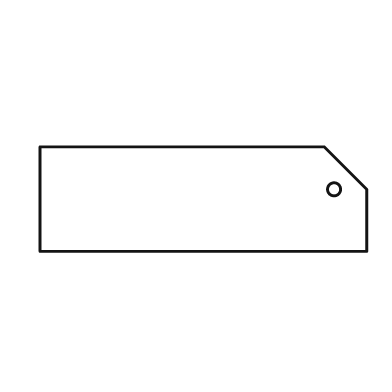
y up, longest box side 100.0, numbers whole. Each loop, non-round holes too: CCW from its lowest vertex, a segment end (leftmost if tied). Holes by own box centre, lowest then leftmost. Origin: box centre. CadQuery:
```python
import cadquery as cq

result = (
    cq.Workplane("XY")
    .moveTo(-50.0, -16.0)
    .lineTo(50.0, -16.0)
    .lineTo(50.0, 3.0)
    .lineTo(37.0, 16.0)
    .lineTo(-50.0, 16.0)
    .close()
    .moveTo(40.0, 3.0)
    .circle(2.0)
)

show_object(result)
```